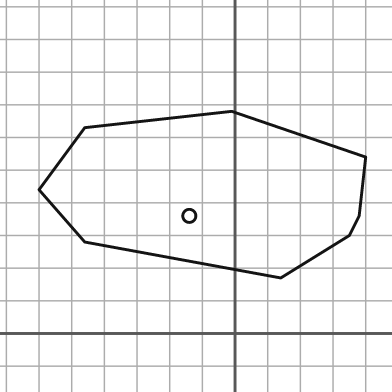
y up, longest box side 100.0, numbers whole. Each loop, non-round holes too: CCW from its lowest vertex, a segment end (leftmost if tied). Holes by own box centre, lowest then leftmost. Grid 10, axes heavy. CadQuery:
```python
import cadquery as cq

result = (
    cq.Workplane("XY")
    .moveTo(14.0, 17.0)
    .lineTo(35.0, 30.0)
    .lineTo(38.0, 36.0)
    .lineTo(40.0, 54.0)
    .lineTo(-1.0, 68.0)
    .lineTo(-46.0, 63.0)
    .lineTo(-60.0, 44.0)
    .lineTo(-46.0, 28.0)
    .close()
    .moveTo(-14.0, 36.0)
    .circle(2.0)
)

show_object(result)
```